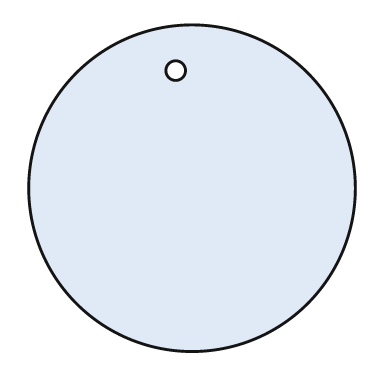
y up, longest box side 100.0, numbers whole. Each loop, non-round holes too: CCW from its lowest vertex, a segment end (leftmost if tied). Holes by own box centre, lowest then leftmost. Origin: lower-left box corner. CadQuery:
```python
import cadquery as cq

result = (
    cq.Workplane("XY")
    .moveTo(50.0, 50.0)
    .circle(50.0)
    .moveTo(45.0, 86.0)
    .circle(3.0)
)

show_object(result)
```